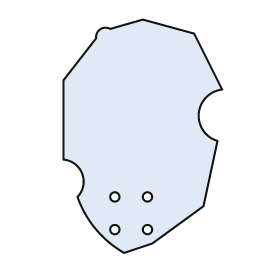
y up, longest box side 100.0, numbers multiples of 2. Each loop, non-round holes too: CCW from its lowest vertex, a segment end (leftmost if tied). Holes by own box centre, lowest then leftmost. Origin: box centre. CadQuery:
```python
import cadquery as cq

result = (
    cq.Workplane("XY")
    .moveTo(-8.0, -50.0)
    .lineTo(4.0, -46.0)
    .lineTo(26.0, -30.0)
    .lineTo(32.0, -2.0)
    .threePointArc((24.0, 10.0), (34.0, 20.0))
    .lineTo(22.0, 44.0)
    .lineTo(0.0, 50.0)
    .lineTo(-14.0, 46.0)
    .threePointArc((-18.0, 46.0), (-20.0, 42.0))
    .lineTo(-34.0, 24.0)
    .lineTo(-34.0, -10.0)
    .threePointArc((-26.0, -16.0), (-28.0, -26.0))
    .threePointArc((-20.0, -40.0), (-8.0, -50.0))
    .close()
    .moveTo(-12.0, -40.0)
    .circle(2.0)
    .moveTo(2.0, -40.0)
    .circle(2.0)
    .moveTo(-12.0, -26.0)
    .circle(2.0)
    .moveTo(2.0, -26.0)
    .circle(2.0)
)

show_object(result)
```